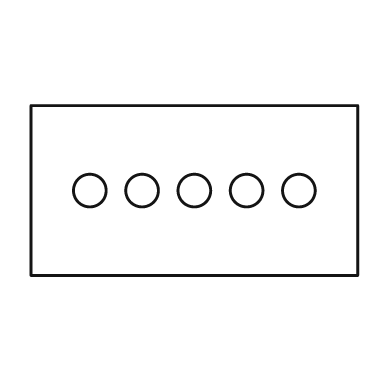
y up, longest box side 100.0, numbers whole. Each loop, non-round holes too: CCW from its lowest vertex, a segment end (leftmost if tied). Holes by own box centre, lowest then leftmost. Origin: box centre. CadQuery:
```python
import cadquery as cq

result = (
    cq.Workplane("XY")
    .moveTo(-50.0, -26.0)
    .lineTo(50.0, -26.0)
    .lineTo(50.0, 26.0)
    .lineTo(-50.0, 26.0)
    .close()
    .moveTo(-32.0, 0.0)
    .circle(5.0)
    .moveTo(-16.0, 0.0)
    .circle(5.0)
    .moveTo(0.0, 0.0)
    .circle(5.0)
    .moveTo(16.0, 0.0)
    .circle(5.0)
    .moveTo(32.0, 0.0)
    .circle(5.0)
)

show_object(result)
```